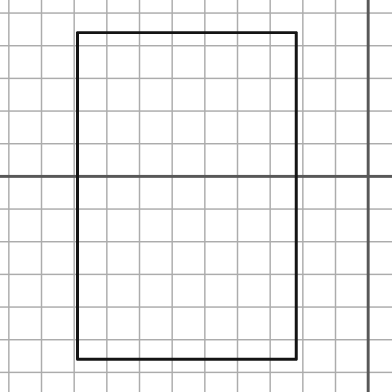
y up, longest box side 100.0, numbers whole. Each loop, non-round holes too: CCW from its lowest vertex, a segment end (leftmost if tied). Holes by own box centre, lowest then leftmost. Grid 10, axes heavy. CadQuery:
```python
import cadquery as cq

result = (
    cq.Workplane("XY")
    .moveTo(-89.0, -56.0)
    .lineTo(-22.0, -56.0)
    .lineTo(-22.0, 44.0)
    .lineTo(-89.0, 44.0)
    .close()
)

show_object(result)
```